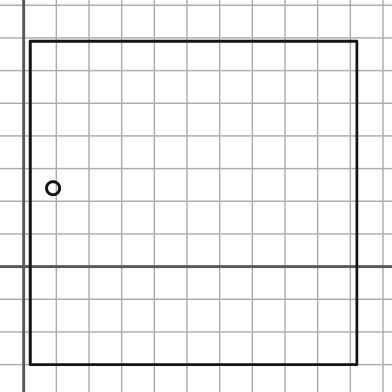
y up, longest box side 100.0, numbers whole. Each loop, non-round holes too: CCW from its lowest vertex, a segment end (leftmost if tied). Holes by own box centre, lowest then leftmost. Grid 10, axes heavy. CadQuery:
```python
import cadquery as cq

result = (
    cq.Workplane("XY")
    .moveTo(2.0, -30.0)
    .lineTo(102.0, -30.0)
    .lineTo(102.0, 69.0)
    .lineTo(2.0, 69.0)
    .close()
    .moveTo(9.0, 24.0)
    .circle(2.0)
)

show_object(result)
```